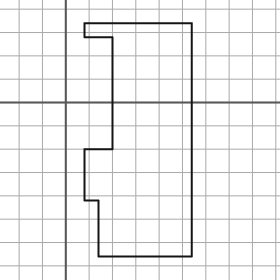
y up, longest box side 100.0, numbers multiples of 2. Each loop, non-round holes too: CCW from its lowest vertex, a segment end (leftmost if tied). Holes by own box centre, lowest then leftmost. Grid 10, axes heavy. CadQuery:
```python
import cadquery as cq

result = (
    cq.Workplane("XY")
    .moveTo(14.0, -66.0)
    .lineTo(54.0, -66.0)
    .lineTo(54.0, 34.0)
    .lineTo(8.0, 34.0)
    .lineTo(8.0, 28.0)
    .lineTo(20.0, 28.0)
    .lineTo(20.0, -20.0)
    .lineTo(8.0, -20.0)
    .lineTo(8.0, -42.0)
    .lineTo(14.0, -42.0)
    .close()
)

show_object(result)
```